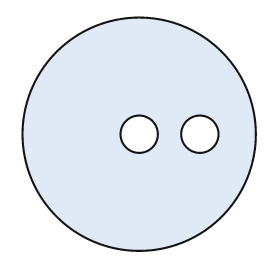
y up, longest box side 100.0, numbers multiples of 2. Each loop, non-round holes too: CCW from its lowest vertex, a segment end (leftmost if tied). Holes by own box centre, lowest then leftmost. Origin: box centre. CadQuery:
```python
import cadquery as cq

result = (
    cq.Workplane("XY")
    .moveTo(0.0, 0.0)
    .circle(50.0)
    .moveTo(0.0, 0.0)
    .circle(8.0)
    .moveTo(26.0, 0.0)
    .circle(8.0)
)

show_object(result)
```